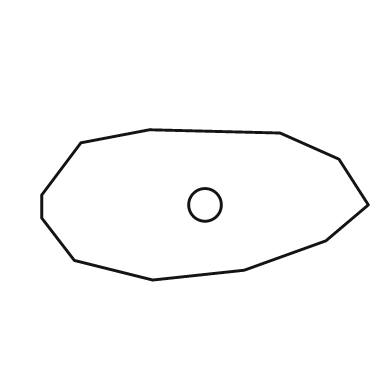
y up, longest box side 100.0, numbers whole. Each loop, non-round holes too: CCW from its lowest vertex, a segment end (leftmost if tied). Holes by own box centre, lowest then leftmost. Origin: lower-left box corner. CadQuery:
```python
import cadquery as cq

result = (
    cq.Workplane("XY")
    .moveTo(34.0, 0.0)
    .lineTo(62.0, 3.0)
    .lineTo(87.0, 12.0)
    .lineTo(100.0, 23.0)
    .lineTo(91.0, 37.0)
    .lineTo(73.0, 45.0)
    .lineTo(33.0, 46.0)
    .lineTo(12.0, 42.0)
    .lineTo(0.0, 26.0)
    .lineTo(0.0, 19.0)
    .lineTo(10.0, 6.0)
    .close()
    .moveTo(50.0, 23.0)
    .circle(5.0)
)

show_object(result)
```